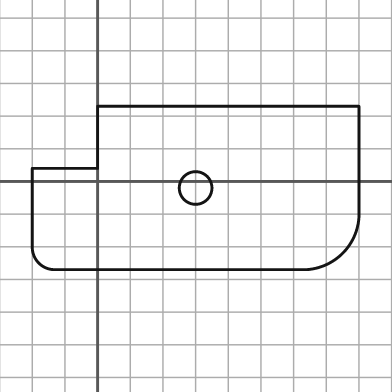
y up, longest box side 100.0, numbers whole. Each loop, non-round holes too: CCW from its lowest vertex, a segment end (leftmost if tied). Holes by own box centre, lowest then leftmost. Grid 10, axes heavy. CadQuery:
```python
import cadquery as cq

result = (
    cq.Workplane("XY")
    .moveTo(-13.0, -27.0)
    .lineTo(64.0, -27.0)
    .threePointArc((75.0, -22.0), (80.0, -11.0))
    .lineTo(80.0, 23.0)
    .lineTo(0.0, 23.0)
    .lineTo(0.0, 4.0)
    .lineTo(-20.0, 4.0)
    .lineTo(-20.0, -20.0)
    .threePointArc((-18.0, -25.0), (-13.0, -27.0))
    .close()
    .moveTo(30.0, -2.0)
    .circle(5.0)
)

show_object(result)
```